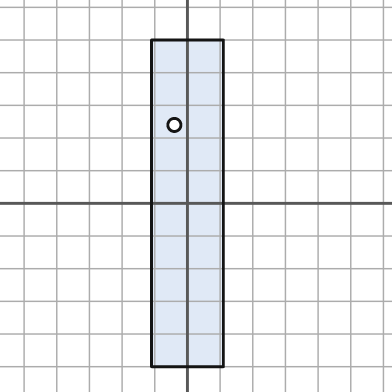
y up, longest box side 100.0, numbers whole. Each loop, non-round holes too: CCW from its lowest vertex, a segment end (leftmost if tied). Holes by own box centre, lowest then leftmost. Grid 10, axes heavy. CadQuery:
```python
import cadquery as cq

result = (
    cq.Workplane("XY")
    .moveTo(-11.0, -50.0)
    .lineTo(11.0, -50.0)
    .lineTo(11.0, 50.0)
    .lineTo(-11.0, 50.0)
    .close()
    .moveTo(-4.0, 24.0)
    .circle(2.0)
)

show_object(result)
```